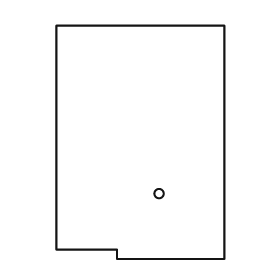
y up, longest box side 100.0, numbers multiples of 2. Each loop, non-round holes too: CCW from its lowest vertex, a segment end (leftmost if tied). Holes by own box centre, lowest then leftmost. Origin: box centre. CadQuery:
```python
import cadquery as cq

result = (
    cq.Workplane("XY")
    .moveTo(-10.0, -50.0)
    .lineTo(36.0, -50.0)
    .lineTo(36.0, 50.0)
    .lineTo(-36.0, 50.0)
    .lineTo(-36.0, -46.0)
    .lineTo(-10.0, -46.0)
    .close()
    .moveTo(8.0, -22.0)
    .circle(2.0)
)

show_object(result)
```